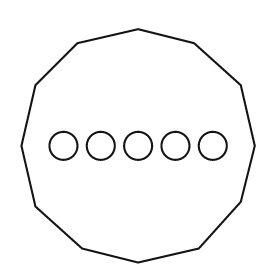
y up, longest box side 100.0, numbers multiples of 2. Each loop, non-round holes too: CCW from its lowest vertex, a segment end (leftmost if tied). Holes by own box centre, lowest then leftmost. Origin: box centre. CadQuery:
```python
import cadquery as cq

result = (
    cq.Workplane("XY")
    .moveTo(0.0, -50.0)
    .lineTo(26.0, -44.0)
    .lineTo(44.0, -24.0)
    .lineTo(50.0, 0.0)
    .lineTo(44.0, 26.0)
    .lineTo(24.0, 44.0)
    .lineTo(0.0, 50.0)
    .lineTo(-26.0, 44.0)
    .lineTo(-44.0, 26.0)
    .lineTo(-50.0, 0.0)
    .lineTo(-44.0, -26.0)
    .lineTo(-24.0, -44.0)
    .close()
    .moveTo(-32.0, 0.0)
    .circle(6.0)
    .moveTo(-16.0, 0.0)
    .circle(6.0)
    .moveTo(0.0, 0.0)
    .circle(6.0)
    .moveTo(16.0, 0.0)
    .circle(6.0)
    .moveTo(32.0, 0.0)
    .circle(6.0)
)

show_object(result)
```